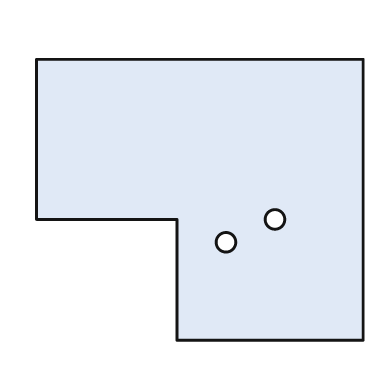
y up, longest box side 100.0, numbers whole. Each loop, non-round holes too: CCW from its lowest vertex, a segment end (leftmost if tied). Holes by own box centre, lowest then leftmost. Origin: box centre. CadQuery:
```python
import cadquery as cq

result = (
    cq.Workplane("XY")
    .moveTo(-7.0, -43.0)
    .lineTo(50.0, -43.0)
    .lineTo(50.0, 43.0)
    .lineTo(-50.0, 43.0)
    .lineTo(-50.0, -6.0)
    .lineTo(-7.0, -6.0)
    .close()
    .moveTo(8.0, -13.0)
    .circle(3.0)
    .moveTo(23.0, -6.0)
    .circle(3.0)
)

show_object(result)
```